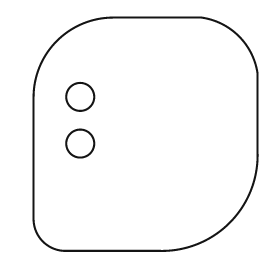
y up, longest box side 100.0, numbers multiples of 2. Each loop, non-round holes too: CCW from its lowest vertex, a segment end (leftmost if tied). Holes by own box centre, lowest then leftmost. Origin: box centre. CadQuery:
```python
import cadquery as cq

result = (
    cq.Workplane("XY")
    .moveTo(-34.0, -50.0)
    .lineTo(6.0, -50.0)
    .threePointArc((36.0, -38.0), (48.0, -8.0))
    .lineTo(48.0, 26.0)
    .threePointArc((40.0, 42.0), (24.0, 50.0))
    .lineTo(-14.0, 50.0)
    .threePointArc((-38.0, 40.0), (-48.0, 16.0))
    .lineTo(-48.0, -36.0)
    .threePointArc((-44.0, -46.0), (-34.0, -50.0))
    .close()
    .moveTo(-28.0, -4.0)
    .circle(6.0)
    .moveTo(-28.0, 16.0)
    .circle(6.0)
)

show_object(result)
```